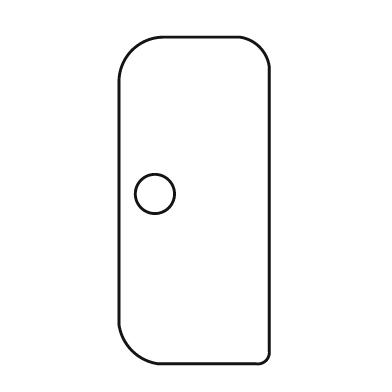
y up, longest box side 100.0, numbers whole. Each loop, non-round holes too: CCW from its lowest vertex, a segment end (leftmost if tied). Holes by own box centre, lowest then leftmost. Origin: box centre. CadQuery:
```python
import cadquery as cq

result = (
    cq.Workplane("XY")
    .moveTo(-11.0, -50.0)
    .lineTo(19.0, -50.0)
    .threePointArc((22.0, -49.0), (23.0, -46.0))
    .lineTo(23.0, 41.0)
    .threePointArc((20.0, 47.0), (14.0, 50.0))
    .lineTo(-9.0, 50.0)
    .threePointArc((-19.0, 46.0), (-23.0, 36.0))
    .lineTo(-23.0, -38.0)
    .threePointArc((-19.0, -46.0), (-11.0, -50.0))
    .close()
    .moveTo(-12.0, 2.0)
    .circle(6.0)
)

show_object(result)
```